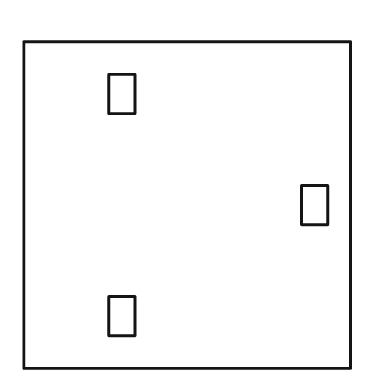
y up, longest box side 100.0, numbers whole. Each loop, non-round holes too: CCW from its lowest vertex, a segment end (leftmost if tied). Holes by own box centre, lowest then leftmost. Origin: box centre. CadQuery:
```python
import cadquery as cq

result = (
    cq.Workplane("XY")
    .moveTo(-50.0, -50.0)
    .lineTo(50.0, -50.0)
    .lineTo(50.0, 50.0)
    .lineTo(-50.0, 50.0)
    .close()
    .moveTo(-24.0, -40.0)
    .lineTo(-16.0, -40.0)
    .lineTo(-16.0, -28.0)
    .lineTo(-24.0, -28.0)
    .close()
    .moveTo(35.0, -6.0)
    .lineTo(43.0, -6.0)
    .lineTo(43.0, 6.0)
    .lineTo(35.0, 6.0)
    .close()
    .moveTo(-24.0, 28.0)
    .lineTo(-16.0, 28.0)
    .lineTo(-16.0, 40.0)
    .lineTo(-24.0, 40.0)
    .close()
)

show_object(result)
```